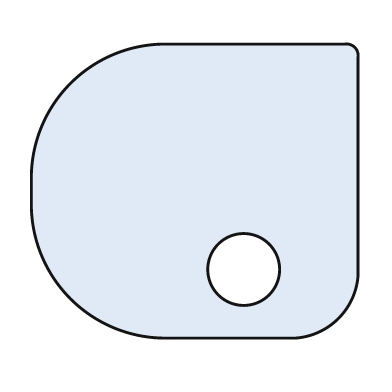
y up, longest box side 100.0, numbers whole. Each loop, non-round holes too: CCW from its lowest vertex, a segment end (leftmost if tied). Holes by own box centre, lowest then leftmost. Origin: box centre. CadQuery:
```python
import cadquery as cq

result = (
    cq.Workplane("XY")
    .moveTo(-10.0, -45.0)
    .lineTo(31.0, -45.0)
    .threePointArc((44.0, -39.0), (50.0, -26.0))
    .lineTo(50.0, 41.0)
    .threePointArc((49.0, 44.0), (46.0, 45.0))
    .lineTo(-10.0, 45.0)
    .threePointArc((-38.0, 33.0), (-50.0, 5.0))
    .lineTo(-50.0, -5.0)
    .threePointArc((-38.0, -33.0), (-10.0, -45.0))
    .close()
    .moveTo(15.0, -24.0)
    .circle(11.0)
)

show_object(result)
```